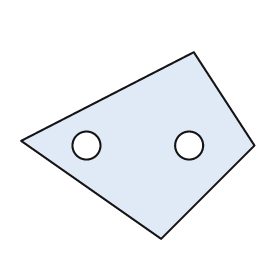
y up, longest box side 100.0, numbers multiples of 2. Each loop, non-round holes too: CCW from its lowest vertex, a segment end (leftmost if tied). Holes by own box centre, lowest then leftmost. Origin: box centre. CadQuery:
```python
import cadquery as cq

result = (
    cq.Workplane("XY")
    .moveTo(10.0, -40.0)
    .lineTo(50.0, 0.0)
    .lineTo(24.0, 40.0)
    .lineTo(-50.0, 2.0)
    .close()
    .moveTo(-22.0, 0.0)
    .circle(6.0)
    .moveTo(22.0, 0.0)
    .circle(6.0)
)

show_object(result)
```